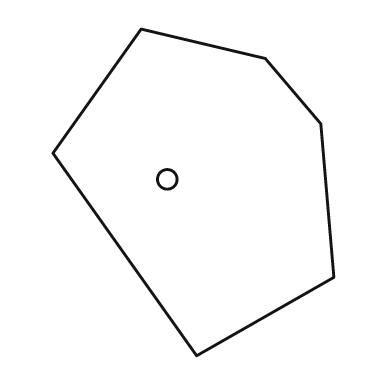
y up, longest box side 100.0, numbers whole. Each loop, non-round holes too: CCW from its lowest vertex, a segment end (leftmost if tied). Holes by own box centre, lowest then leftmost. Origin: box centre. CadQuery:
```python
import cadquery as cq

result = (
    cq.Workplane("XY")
    .moveTo(1.0, -50.0)
    .lineTo(43.0, -26.0)
    .lineTo(39.0, 21.0)
    .lineTo(22.0, 41.0)
    .lineTo(-16.0, 50.0)
    .lineTo(-43.0, 12.0)
    .close()
    .moveTo(-8.0, 4.0)
    .circle(3.0)
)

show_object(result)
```